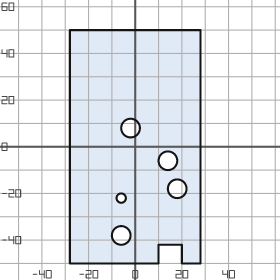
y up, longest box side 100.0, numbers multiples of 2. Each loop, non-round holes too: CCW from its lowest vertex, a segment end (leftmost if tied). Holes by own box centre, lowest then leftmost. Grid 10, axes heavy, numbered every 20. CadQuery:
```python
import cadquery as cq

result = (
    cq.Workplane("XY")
    .moveTo(-28.0, -50.0)
    .lineTo(10.0, -50.0)
    .lineTo(10.0, -42.0)
    .lineTo(20.0, -42.0)
    .lineTo(20.0, -50.0)
    .lineTo(28.0, -50.0)
    .lineTo(28.0, 50.0)
    .lineTo(-28.0, 50.0)
    .close()
    .moveTo(-6.0, -38.0)
    .circle(4.0)
    .moveTo(-6.0, -22.0)
    .circle(2.0)
    .moveTo(18.0, -18.0)
    .circle(4.0)
    .moveTo(14.0, -6.0)
    .circle(4.0)
    .moveTo(-2.0, 8.0)
    .circle(4.0)
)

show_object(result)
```